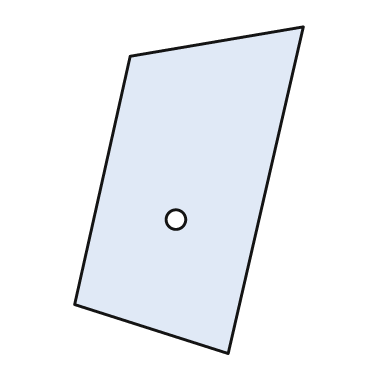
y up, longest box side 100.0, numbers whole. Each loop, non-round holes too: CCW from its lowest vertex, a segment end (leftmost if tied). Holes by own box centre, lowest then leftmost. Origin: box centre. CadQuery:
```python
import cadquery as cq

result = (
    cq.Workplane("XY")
    .moveTo(12.0, -50.0)
    .lineTo(35.0, 50.0)
    .lineTo(-18.0, 41.0)
    .lineTo(-35.0, -35.0)
    .close()
    .moveTo(-4.0, -9.0)
    .circle(3.0)
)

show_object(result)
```